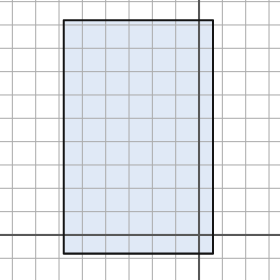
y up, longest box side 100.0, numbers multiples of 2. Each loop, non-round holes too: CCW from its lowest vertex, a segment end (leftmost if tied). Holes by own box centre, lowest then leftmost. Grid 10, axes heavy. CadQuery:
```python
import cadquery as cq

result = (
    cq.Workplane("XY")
    .moveTo(-58.0, -8.0)
    .lineTo(6.0, -8.0)
    .lineTo(6.0, 92.0)
    .lineTo(-58.0, 92.0)
    .close()
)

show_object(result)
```